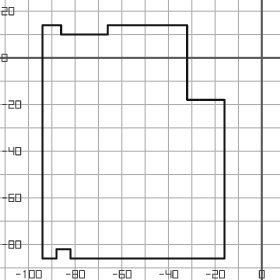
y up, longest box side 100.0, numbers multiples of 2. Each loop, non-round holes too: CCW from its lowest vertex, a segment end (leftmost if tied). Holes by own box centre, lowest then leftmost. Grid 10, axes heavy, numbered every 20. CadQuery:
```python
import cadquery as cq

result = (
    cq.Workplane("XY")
    .moveTo(-94.0, -86.0)
    .lineTo(-88.0, -86.0)
    .lineTo(-88.0, -82.0)
    .lineTo(-82.0, -82.0)
    .lineTo(-82.0, -86.0)
    .lineTo(-16.0, -86.0)
    .lineTo(-16.0, -18.0)
    .lineTo(-32.0, -18.0)
    .lineTo(-32.0, 14.0)
    .lineTo(-66.0, 14.0)
    .lineTo(-66.0, 10.0)
    .lineTo(-86.0, 10.0)
    .lineTo(-86.0, 14.0)
    .lineTo(-94.0, 14.0)
    .close()
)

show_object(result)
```